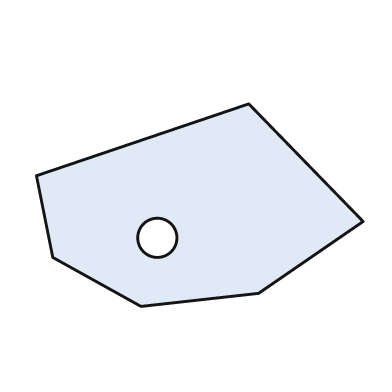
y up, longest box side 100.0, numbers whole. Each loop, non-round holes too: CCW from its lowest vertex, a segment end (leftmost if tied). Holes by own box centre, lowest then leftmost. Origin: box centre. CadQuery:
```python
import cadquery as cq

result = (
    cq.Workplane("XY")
    .moveTo(-18.0, -31.0)
    .lineTo(18.0, -27.0)
    .lineTo(50.0, -5.0)
    .lineTo(15.0, 31.0)
    .lineTo(-50.0, 9.0)
    .lineTo(-45.0, -16.0)
    .close()
    .moveTo(-13.0, -10.0)
    .circle(6.0)
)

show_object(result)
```